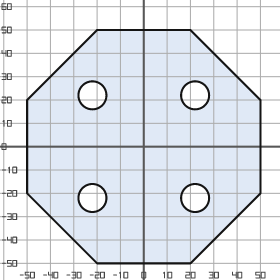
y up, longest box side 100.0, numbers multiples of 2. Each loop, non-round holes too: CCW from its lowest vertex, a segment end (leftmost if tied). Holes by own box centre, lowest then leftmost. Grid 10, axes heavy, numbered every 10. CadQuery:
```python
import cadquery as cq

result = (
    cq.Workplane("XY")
    .moveTo(-20.0, -50.0)
    .lineTo(20.0, -50.0)
    .lineTo(50.0, -20.0)
    .lineTo(50.0, 20.0)
    .lineTo(20.0, 50.0)
    .lineTo(-20.0, 50.0)
    .lineTo(-50.0, 20.0)
    .lineTo(-50.0, -20.0)
    .close()
    .moveTo(-22.0, -22.0)
    .circle(6.0)
    .moveTo(22.0, -22.0)
    .circle(6.0)
    .moveTo(-22.0, 22.0)
    .circle(6.0)
    .moveTo(22.0, 22.0)
    .circle(6.0)
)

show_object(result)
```